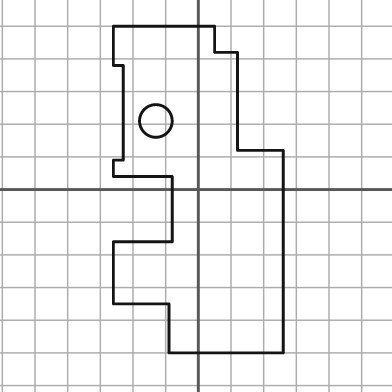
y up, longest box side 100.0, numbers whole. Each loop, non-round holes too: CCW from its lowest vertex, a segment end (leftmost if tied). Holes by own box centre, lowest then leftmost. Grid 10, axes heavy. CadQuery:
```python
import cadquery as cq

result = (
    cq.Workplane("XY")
    .moveTo(-9.0, -50.0)
    .lineTo(26.0, -50.0)
    .lineTo(26.0, 12.0)
    .lineTo(12.0, 12.0)
    .lineTo(12.0, 42.0)
    .lineTo(5.0, 42.0)
    .lineTo(5.0, 50.0)
    .lineTo(-26.0, 50.0)
    .lineTo(-26.0, 38.0)
    .lineTo(-23.0, 38.0)
    .lineTo(-23.0, 9.0)
    .lineTo(-26.0, 9.0)
    .lineTo(-26.0, 4.0)
    .lineTo(-8.0, 4.0)
    .lineTo(-8.0, -16.0)
    .lineTo(-26.0, -16.0)
    .lineTo(-26.0, -35.0)
    .lineTo(-9.0, -35.0)
    .close()
    .moveTo(-13.0, 21.0)
    .circle(5.0)
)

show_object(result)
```